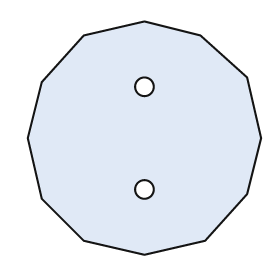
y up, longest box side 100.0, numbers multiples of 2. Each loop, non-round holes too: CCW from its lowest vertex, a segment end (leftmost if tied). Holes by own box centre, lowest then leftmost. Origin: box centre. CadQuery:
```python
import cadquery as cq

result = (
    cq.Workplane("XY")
    .moveTo(0.0, -50.0)
    .lineTo(26.0, -44.0)
    .lineTo(44.0, -24.0)
    .lineTo(50.0, 0.0)
    .lineTo(44.0, 26.0)
    .lineTo(24.0, 44.0)
    .lineTo(0.0, 50.0)
    .lineTo(-26.0, 44.0)
    .lineTo(-44.0, 24.0)
    .lineTo(-50.0, 0.0)
    .lineTo(-44.0, -26.0)
    .lineTo(-26.0, -44.0)
    .close()
    .moveTo(0.0, -22.0)
    .circle(4.0)
    .moveTo(0.0, 22.0)
    .circle(4.0)
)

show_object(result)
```